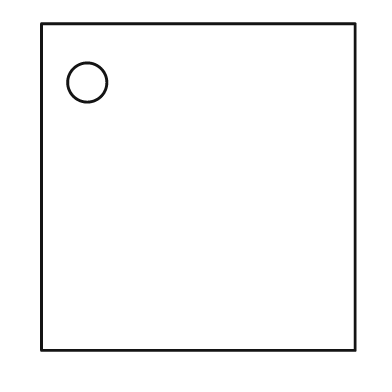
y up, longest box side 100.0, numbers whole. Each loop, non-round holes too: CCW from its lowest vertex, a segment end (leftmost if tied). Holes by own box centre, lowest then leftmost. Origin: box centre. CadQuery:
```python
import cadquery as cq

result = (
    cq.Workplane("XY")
    .moveTo(-48.0, -50.0)
    .lineTo(48.0, -50.0)
    .lineTo(48.0, 50.0)
    .lineTo(-48.0, 50.0)
    .close()
    .moveTo(-34.0, 32.0)
    .circle(6.0)
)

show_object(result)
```